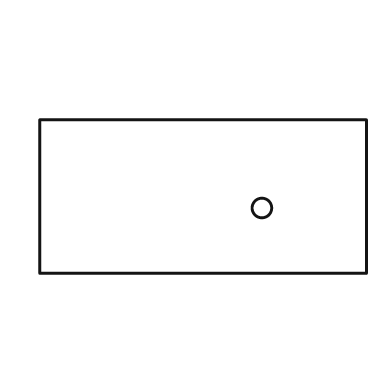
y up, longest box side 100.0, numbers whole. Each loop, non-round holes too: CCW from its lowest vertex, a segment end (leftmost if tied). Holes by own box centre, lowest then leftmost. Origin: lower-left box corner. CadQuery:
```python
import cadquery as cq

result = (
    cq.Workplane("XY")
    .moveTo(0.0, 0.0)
    .lineTo(100.0, 0.0)
    .lineTo(100.0, 47.0)
    .lineTo(0.0, 47.0)
    .close()
    .moveTo(68.0, 20.0)
    .circle(3.0)
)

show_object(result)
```